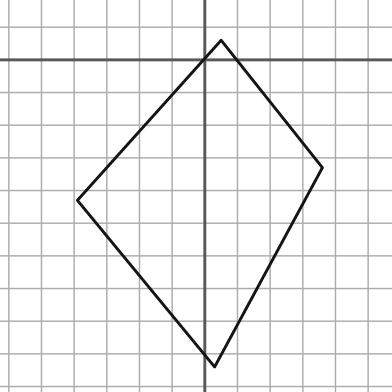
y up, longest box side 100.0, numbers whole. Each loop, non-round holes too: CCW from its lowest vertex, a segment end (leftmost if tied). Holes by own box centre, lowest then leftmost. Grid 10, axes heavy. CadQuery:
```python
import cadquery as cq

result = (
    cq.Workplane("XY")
    .moveTo(3.0, -94.0)
    .lineTo(36.0, -33.0)
    .lineTo(5.0, 6.0)
    .lineTo(-39.0, -43.0)
    .close()
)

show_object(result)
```